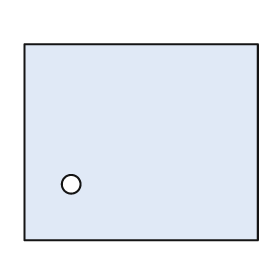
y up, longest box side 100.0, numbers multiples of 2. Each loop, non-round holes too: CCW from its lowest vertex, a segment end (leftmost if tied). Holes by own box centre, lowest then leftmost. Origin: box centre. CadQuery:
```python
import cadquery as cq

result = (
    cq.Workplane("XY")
    .moveTo(-50.0, -42.0)
    .lineTo(50.0, -42.0)
    .lineTo(50.0, 42.0)
    .lineTo(-50.0, 42.0)
    .close()
    .moveTo(-30.0, -18.0)
    .circle(4.0)
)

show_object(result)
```